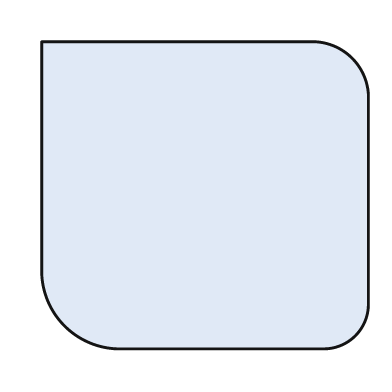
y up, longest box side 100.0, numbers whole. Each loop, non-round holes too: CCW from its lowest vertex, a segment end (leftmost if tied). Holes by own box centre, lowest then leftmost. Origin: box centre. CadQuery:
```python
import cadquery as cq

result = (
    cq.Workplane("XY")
    .moveTo(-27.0, -47.0)
    .lineTo(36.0, -47.0)
    .threePointArc((46.0, -43.0), (50.0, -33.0))
    .lineTo(50.0, 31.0)
    .threePointArc((45.0, 42.0), (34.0, 47.0))
    .lineTo(-50.0, 47.0)
    .lineTo(-50.0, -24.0)
    .threePointArc((-43.0, -40.0), (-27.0, -47.0))
    .close()
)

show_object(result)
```